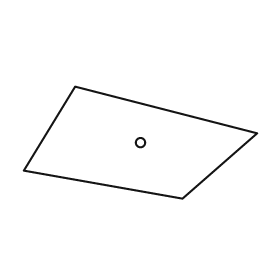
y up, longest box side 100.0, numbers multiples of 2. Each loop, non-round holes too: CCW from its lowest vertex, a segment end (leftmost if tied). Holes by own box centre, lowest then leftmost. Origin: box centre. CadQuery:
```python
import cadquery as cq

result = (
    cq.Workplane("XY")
    .moveTo(18.0, -24.0)
    .lineTo(50.0, 4.0)
    .lineTo(-28.0, 24.0)
    .lineTo(-50.0, -12.0)
    .close()
    .moveTo(0.0, 0.0)
    .circle(2.0)
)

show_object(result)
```